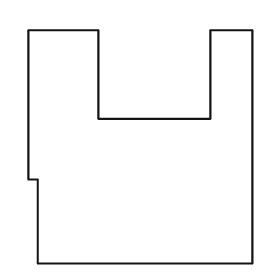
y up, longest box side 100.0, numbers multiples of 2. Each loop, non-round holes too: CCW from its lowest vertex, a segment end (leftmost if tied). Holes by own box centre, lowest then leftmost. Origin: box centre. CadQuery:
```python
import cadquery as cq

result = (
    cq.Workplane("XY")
    .moveTo(-44.0, -50.0)
    .lineTo(48.0, -50.0)
    .lineTo(48.0, 50.0)
    .lineTo(30.0, 50.0)
    .lineTo(30.0, 12.0)
    .lineTo(-18.0, 12.0)
    .lineTo(-18.0, 50.0)
    .lineTo(-48.0, 50.0)
    .lineTo(-48.0, -14.0)
    .lineTo(-44.0, -14.0)
    .close()
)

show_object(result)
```